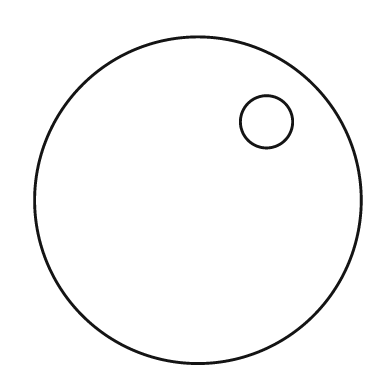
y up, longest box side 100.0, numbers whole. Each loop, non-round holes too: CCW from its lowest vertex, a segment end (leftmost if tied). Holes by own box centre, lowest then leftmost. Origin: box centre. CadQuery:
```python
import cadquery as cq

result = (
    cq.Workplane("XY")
    .moveTo(0.0, 0.0)
    .circle(50.0)
    .moveTo(21.0, 24.0)
    .circle(8.0)
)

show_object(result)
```